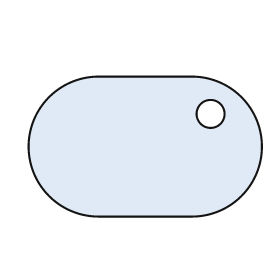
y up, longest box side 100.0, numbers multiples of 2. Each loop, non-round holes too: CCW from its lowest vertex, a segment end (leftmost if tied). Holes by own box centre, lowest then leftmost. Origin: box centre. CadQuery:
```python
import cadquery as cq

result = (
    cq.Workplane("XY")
    .moveTo(-20.0, -30.0)
    .lineTo(20.0, -30.0)
    .threePointArc((50.0, 0.0), (20.0, 30.0))
    .lineTo(-20.0, 30.0)
    .threePointArc((-50.0, 0.0), (-20.0, -30.0))
    .close()
    .moveTo(28.0, 14.0)
    .circle(6.0)
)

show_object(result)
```